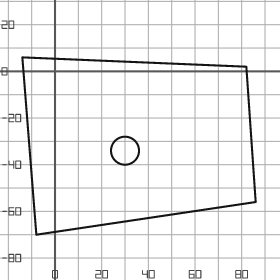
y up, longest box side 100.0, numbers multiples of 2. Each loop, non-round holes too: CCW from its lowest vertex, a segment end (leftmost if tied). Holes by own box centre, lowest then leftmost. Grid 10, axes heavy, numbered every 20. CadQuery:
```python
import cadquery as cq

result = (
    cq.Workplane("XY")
    .moveTo(-8.0, -70.0)
    .lineTo(86.0, -56.0)
    .lineTo(82.0, 2.0)
    .lineTo(-14.0, 6.0)
    .close()
    .moveTo(30.0, -34.0)
    .circle(6.0)
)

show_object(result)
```